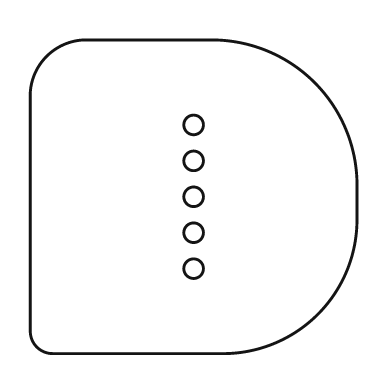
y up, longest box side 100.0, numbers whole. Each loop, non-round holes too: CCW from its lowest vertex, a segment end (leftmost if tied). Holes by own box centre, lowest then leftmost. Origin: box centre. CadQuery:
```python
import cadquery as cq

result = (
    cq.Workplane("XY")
    .moveTo(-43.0, -48.0)
    .lineTo(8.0, -48.0)
    .threePointArc((38.0, -36.0), (50.0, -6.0))
    .lineTo(50.0, 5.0)
    .threePointArc((37.0, 35.0), (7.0, 48.0))
    .lineTo(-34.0, 48.0)
    .threePointArc((-45.0, 43.0), (-50.0, 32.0))
    .lineTo(-50.0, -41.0)
    .threePointArc((-48.0, -46.0), (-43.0, -48.0))
    .close()
    .moveTo(0.0, -22.0)
    .circle(3.0)
    .moveTo(0.0, -11.0)
    .circle(3.0)
    .moveTo(0.0, 0.0)
    .circle(3.0)
    .moveTo(0.0, 11.0)
    .circle(3.0)
    .moveTo(0.0, 22.0)
    .circle(3.0)
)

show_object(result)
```